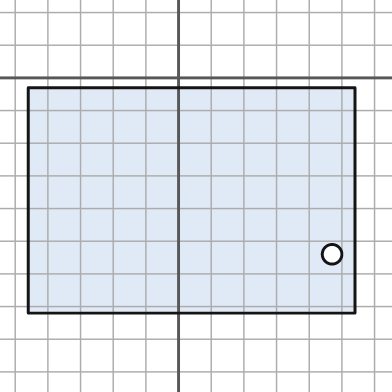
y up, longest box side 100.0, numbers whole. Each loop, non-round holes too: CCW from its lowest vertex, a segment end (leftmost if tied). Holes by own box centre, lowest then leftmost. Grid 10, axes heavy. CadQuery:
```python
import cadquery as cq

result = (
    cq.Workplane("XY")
    .moveTo(-46.0, -72.0)
    .lineTo(54.0, -72.0)
    .lineTo(54.0, -3.0)
    .lineTo(-46.0, -3.0)
    .close()
    .moveTo(47.0, -54.0)
    .circle(3.0)
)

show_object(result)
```